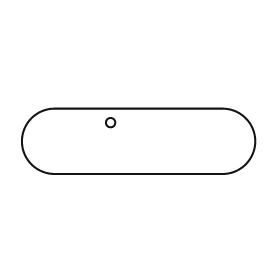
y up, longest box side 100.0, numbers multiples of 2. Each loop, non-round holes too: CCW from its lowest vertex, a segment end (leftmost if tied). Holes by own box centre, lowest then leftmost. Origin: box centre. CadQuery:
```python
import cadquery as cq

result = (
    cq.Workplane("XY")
    .moveTo(-36.0, -14.0)
    .lineTo(36.0, -14.0)
    .threePointArc((50.0, 0.0), (36.0, 14.0))
    .lineTo(-36.0, 14.0)
    .threePointArc((-50.0, 0.0), (-36.0, -14.0))
    .close()
    .moveTo(-12.0, 8.0)
    .circle(2.0)
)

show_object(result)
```